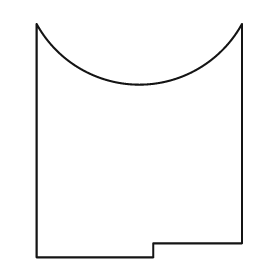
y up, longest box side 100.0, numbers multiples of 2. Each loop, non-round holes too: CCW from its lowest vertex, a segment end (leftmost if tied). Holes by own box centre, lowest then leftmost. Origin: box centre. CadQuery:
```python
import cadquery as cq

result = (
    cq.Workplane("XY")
    .moveTo(-44.0, -50.0)
    .lineTo(6.0, -50.0)
    .lineTo(6.0, -44.0)
    .lineTo(44.0, -44.0)
    .lineTo(44.0, 50.0)
    .threePointArc((0.0, 24.0), (-44.0, 50.0))
    .close()
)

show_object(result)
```